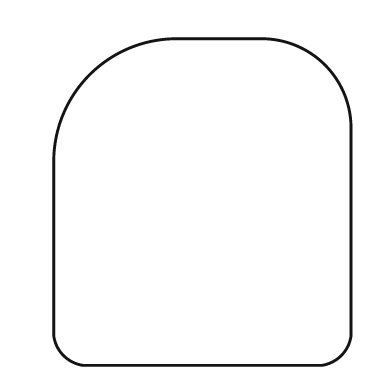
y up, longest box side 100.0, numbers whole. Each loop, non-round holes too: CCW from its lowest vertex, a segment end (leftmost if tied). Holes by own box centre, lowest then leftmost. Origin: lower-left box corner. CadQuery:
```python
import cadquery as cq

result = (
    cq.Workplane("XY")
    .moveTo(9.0, 0.0)
    .lineTo(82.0, 0.0)
    .threePointArc((88.0, 3.0), (91.0, 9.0))
    .lineTo(91.0, 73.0)
    .threePointArc((83.0, 92.0), (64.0, 100.0))
    .lineTo(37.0, 100.0)
    .threePointArc((11.0, 89.0), (0.0, 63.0))
    .lineTo(0.0, 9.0)
    .threePointArc((3.0, 3.0), (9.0, 0.0))
    .close()
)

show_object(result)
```